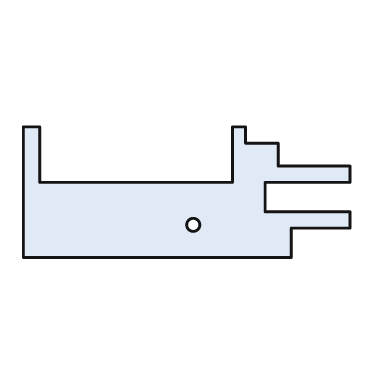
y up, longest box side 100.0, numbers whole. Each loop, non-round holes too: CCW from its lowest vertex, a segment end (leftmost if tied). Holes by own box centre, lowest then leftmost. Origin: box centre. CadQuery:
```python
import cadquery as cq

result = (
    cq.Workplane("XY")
    .moveTo(-50.0, -20.0)
    .lineTo(32.0, -20.0)
    .lineTo(32.0, -11.0)
    .lineTo(50.0, -11.0)
    .lineTo(50.0, -6.0)
    .lineTo(24.0, -6.0)
    .lineTo(24.0, 3.0)
    .lineTo(50.0, 3.0)
    .lineTo(50.0, 8.0)
    .lineTo(28.0, 8.0)
    .lineTo(28.0, 15.0)
    .lineTo(18.0, 15.0)
    .lineTo(18.0, 20.0)
    .lineTo(14.0, 20.0)
    .lineTo(14.0, 3.0)
    .lineTo(-45.0, 3.0)
    .lineTo(-45.0, 20.0)
    .lineTo(-50.0, 20.0)
    .close()
    .moveTo(2.0, -10.0)
    .circle(2.0)
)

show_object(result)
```